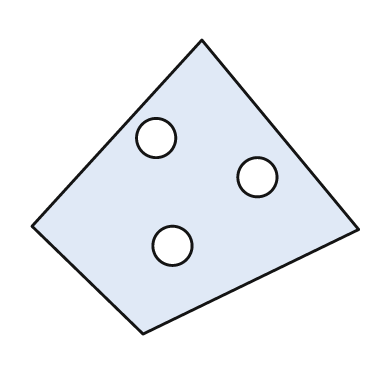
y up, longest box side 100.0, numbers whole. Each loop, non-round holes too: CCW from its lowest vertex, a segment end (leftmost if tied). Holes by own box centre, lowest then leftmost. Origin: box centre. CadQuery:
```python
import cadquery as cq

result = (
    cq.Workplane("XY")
    .moveTo(-16.0, -45.0)
    .lineTo(50.0, -13.0)
    .lineTo(2.0, 45.0)
    .lineTo(-50.0, -12.0)
    .close()
    .moveTo(-7.0, -18.0)
    .circle(6.0)
    .moveTo(19.0, 3.0)
    .circle(6.0)
    .moveTo(-12.0, 15.0)
    .circle(6.0)
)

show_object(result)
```